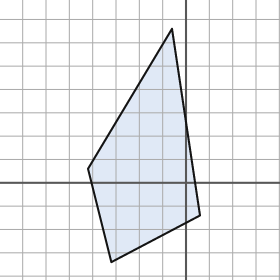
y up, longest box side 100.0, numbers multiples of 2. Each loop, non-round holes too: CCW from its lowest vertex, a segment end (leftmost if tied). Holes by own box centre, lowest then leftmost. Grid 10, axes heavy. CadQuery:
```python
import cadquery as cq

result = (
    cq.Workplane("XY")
    .moveTo(-32.0, -34.0)
    .lineTo(6.0, -14.0)
    .lineTo(-6.0, 66.0)
    .lineTo(-42.0, 6.0)
    .close()
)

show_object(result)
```